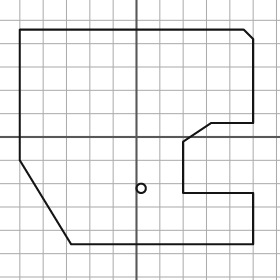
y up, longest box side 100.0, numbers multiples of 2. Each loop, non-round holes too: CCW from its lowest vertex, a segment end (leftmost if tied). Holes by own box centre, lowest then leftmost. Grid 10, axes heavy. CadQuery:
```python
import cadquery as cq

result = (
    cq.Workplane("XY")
    .moveTo(-28.0, -46.0)
    .lineTo(50.0, -46.0)
    .lineTo(50.0, -24.0)
    .lineTo(20.0, -24.0)
    .lineTo(20.0, -2.0)
    .lineTo(32.0, 6.0)
    .lineTo(50.0, 6.0)
    .lineTo(50.0, 42.0)
    .lineTo(46.0, 46.0)
    .lineTo(-50.0, 46.0)
    .lineTo(-50.0, -10.0)
    .close()
    .moveTo(2.0, -22.0)
    .circle(2.0)
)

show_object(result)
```